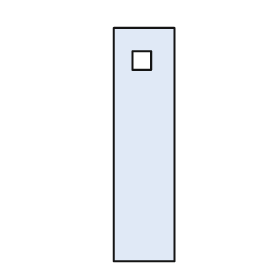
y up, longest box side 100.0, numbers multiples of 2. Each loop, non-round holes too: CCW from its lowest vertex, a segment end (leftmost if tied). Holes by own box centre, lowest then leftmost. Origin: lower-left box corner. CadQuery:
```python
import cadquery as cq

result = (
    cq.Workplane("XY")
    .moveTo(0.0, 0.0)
    .lineTo(26.0, 0.0)
    .lineTo(26.0, 100.0)
    .lineTo(0.0, 100.0)
    .close()
    .moveTo(8.0, 82.0)
    .lineTo(16.0, 82.0)
    .lineTo(16.0, 90.0)
    .lineTo(8.0, 90.0)
    .close()
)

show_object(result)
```